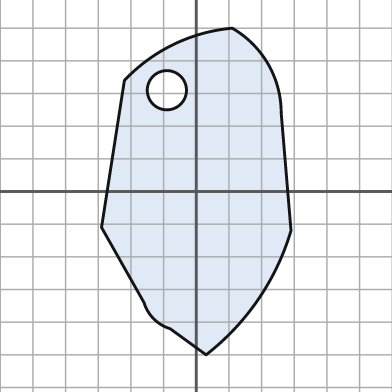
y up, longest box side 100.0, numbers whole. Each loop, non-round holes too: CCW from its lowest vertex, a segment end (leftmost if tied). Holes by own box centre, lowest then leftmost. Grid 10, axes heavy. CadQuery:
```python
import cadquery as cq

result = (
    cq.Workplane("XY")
    .moveTo(3.0, -50.0)
    .threePointArc((19.0, -33.0), (29.0, -12.0))
    .lineTo(26.0, 24.0)
    .threePointArc((22.0, 39.0), (11.0, 50.0))
    .threePointArc((-7.0, 45.0), (-22.0, 34.0))
    .lineTo(-29.0, -11.0)
    .lineTo(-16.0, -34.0)
    .threePointArc((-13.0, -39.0), (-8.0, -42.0))
    .close()
    .moveTo(-9.0, 31.0)
    .circle(6.0)
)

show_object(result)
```